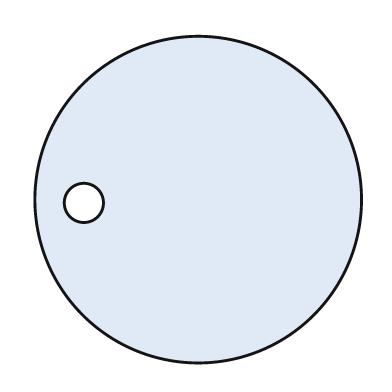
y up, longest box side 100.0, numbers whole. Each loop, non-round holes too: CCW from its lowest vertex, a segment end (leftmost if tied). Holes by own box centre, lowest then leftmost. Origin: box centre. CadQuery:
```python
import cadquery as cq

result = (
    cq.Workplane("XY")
    .moveTo(0.0, 0.0)
    .circle(50.0)
    .moveTo(-35.0, -1.0)
    .circle(6.0)
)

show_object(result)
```